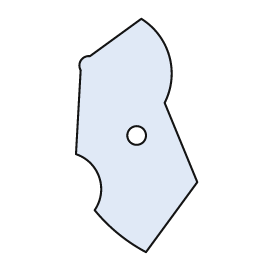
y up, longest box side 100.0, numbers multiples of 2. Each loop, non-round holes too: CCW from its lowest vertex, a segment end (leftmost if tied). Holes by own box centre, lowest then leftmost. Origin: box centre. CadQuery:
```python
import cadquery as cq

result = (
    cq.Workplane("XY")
    .moveTo(4.0, -50.0)
    .lineTo(26.0, -20.0)
    .lineTo(12.0, 14.0)
    .threePointArc((14.0, 34.0), (2.0, 50.0))
    .lineTo(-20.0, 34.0)
    .threePointArc((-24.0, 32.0), (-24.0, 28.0))
    .lineTo(-26.0, -8.0)
    .threePointArc((-16.0, -18.0), (-18.0, -32.0))
    .threePointArc((-8.0, -42.0), (4.0, -50.0))
    .close()
    .moveTo(0.0, 0.0)
    .circle(4.0)
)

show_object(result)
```